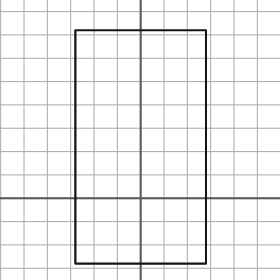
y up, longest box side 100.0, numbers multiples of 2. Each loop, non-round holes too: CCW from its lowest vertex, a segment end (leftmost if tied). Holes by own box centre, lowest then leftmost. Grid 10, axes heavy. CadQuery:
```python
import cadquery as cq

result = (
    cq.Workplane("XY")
    .moveTo(-28.0, -28.0)
    .lineTo(28.0, -28.0)
    .lineTo(28.0, 72.0)
    .lineTo(-28.0, 72.0)
    .close()
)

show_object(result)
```